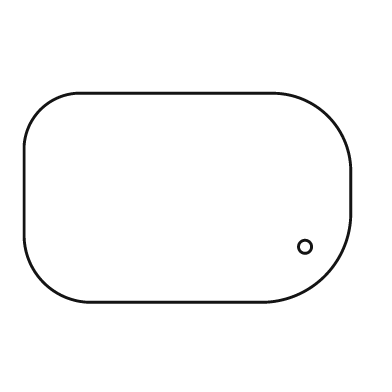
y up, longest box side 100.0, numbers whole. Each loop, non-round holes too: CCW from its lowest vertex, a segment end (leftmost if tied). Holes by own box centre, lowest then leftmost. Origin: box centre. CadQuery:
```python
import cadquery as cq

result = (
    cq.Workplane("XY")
    .moveTo(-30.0, -32.0)
    .lineTo(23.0, -32.0)
    .threePointArc((42.0, -24.0), (50.0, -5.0))
    .lineTo(50.0, 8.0)
    .threePointArc((43.0, 25.0), (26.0, 32.0))
    .lineTo(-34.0, 32.0)
    .threePointArc((-45.0, 27.0), (-50.0, 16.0))
    .lineTo(-50.0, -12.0)
    .threePointArc((-44.0, -26.0), (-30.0, -32.0))
    .close()
    .moveTo(36.0, -15.0)
    .circle(2.0)
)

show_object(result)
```